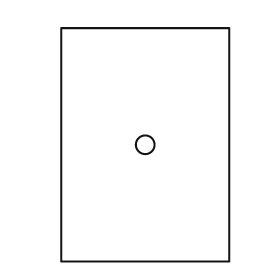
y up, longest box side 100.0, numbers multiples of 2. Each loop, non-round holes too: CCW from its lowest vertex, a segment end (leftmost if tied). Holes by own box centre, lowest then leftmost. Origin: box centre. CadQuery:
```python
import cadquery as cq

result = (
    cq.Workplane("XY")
    .moveTo(-36.0, -50.0)
    .lineTo(36.0, -50.0)
    .lineTo(36.0, 50.0)
    .lineTo(-36.0, 50.0)
    .close()
    .moveTo(0.0, 0.0)
    .circle(4.0)
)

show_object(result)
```